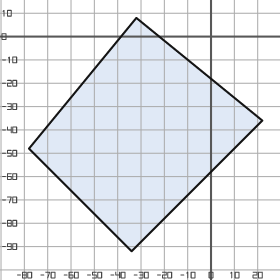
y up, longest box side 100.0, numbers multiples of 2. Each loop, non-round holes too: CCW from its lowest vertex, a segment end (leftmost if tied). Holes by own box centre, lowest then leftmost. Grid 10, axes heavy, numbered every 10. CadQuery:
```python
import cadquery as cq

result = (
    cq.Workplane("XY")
    .moveTo(-34.0, -92.0)
    .lineTo(22.0, -36.0)
    .lineTo(-32.0, 8.0)
    .lineTo(-78.0, -48.0)
    .close()
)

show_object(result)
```